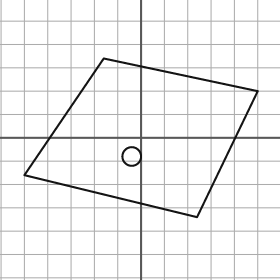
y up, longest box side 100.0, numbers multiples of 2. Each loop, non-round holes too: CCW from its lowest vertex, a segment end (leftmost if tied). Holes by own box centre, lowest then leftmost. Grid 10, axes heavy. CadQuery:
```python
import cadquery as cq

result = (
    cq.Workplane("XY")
    .moveTo(24.0, -34.0)
    .lineTo(50.0, 20.0)
    .lineTo(-16.0, 34.0)
    .lineTo(-50.0, -16.0)
    .close()
    .moveTo(-4.0, -8.0)
    .circle(4.0)
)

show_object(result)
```